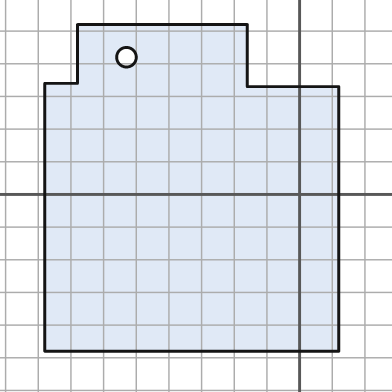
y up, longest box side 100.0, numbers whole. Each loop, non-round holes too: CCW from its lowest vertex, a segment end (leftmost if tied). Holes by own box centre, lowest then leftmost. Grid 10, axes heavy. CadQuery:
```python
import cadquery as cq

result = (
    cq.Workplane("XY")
    .moveTo(-78.0, -48.0)
    .lineTo(12.0, -48.0)
    .lineTo(12.0, 33.0)
    .lineTo(-16.0, 33.0)
    .lineTo(-16.0, 52.0)
    .lineTo(-68.0, 52.0)
    .lineTo(-68.0, 34.0)
    .lineTo(-78.0, 34.0)
    .close()
    .moveTo(-53.0, 42.0)
    .circle(3.0)
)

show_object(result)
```